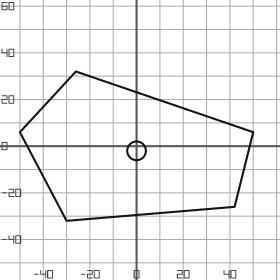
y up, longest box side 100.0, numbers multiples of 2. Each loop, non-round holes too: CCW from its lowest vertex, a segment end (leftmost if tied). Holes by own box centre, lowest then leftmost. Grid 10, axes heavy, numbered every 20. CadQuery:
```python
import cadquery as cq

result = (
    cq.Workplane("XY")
    .moveTo(-30.0, -32.0)
    .lineTo(42.0, -26.0)
    .lineTo(50.0, 6.0)
    .lineTo(-26.0, 32.0)
    .lineTo(-50.0, 6.0)
    .close()
    .moveTo(0.0, -2.0)
    .circle(4.0)
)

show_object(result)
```